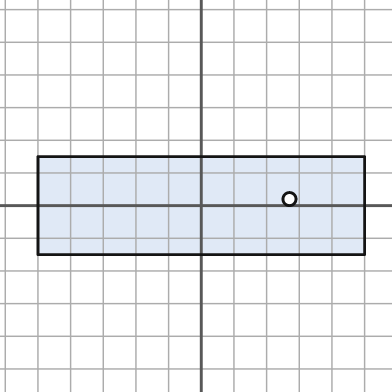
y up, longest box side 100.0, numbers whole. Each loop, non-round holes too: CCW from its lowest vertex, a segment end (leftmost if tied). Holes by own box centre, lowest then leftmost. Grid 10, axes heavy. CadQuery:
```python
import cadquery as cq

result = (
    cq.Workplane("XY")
    .moveTo(-50.0, -15.0)
    .lineTo(50.0, -15.0)
    .lineTo(50.0, 15.0)
    .lineTo(-50.0, 15.0)
    .close()
    .moveTo(27.0, 2.0)
    .circle(2.0)
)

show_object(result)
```